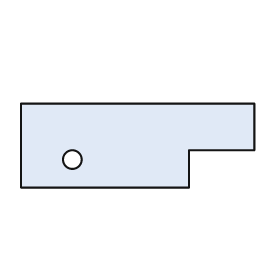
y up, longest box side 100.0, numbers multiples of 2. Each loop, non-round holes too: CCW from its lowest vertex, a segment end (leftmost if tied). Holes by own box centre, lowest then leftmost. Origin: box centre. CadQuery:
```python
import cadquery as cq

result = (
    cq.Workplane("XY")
    .moveTo(-50.0, -18.0)
    .lineTo(22.0, -18.0)
    .lineTo(22.0, -2.0)
    .lineTo(50.0, -2.0)
    .lineTo(50.0, 18.0)
    .lineTo(-50.0, 18.0)
    .close()
    .moveTo(-28.0, -6.0)
    .circle(4.0)
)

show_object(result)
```